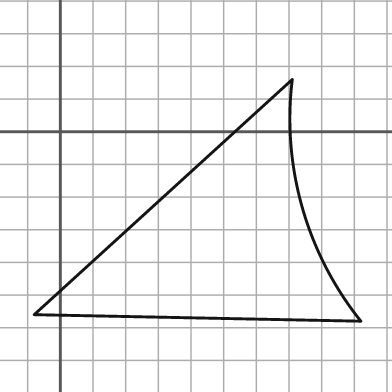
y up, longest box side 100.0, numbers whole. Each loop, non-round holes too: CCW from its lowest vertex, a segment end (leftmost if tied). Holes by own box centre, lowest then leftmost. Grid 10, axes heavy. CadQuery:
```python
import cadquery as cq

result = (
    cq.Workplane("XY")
    .moveTo(92.0, -58.0)
    .threePointArc((74.0, -23.0), (71.0, 16.0))
    .lineTo(-8.0, -56.0)
    .close()
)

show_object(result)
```